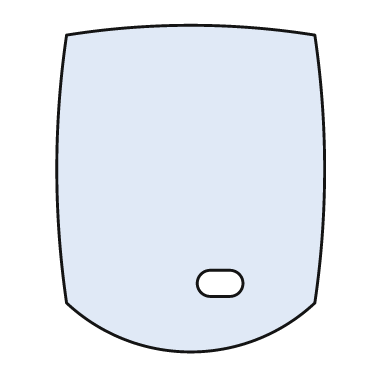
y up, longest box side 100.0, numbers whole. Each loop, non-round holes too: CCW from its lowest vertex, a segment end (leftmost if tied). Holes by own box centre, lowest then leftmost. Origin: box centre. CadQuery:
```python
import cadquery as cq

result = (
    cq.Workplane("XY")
    .moveTo(-38.0, -35.0)
    .threePointArc((0.0, -50.0), (38.0, -35.0))
    .threePointArc((41.0, 6.0), (38.0, 47.0))
    .threePointArc((0.0, 50.0), (-38.0, 47.0))
    .threePointArc((-41.0, 6.0), (-38.0, -35.0))
    .close()
    .moveTo(6.0, -33.0)
    .lineTo(12.0, -33.0)
    .threePointArc((16.0, -29.0), (12.0, -25.0))
    .lineTo(6.0, -25.0)
    .threePointArc((2.0, -29.0), (6.0, -33.0))
    .close()
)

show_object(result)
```